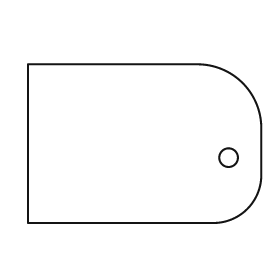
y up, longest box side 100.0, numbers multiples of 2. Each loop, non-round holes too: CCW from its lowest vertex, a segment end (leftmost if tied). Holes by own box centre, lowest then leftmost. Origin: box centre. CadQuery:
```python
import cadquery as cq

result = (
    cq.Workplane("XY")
    .moveTo(-50.0, -34.0)
    .lineTo(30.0, -34.0)
    .threePointArc((44.0, -28.0), (50.0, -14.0))
    .lineTo(50.0, 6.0)
    .threePointArc((42.0, 26.0), (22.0, 34.0))
    .lineTo(-50.0, 34.0)
    .close()
    .moveTo(36.0, -6.0)
    .circle(4.0)
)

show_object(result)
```